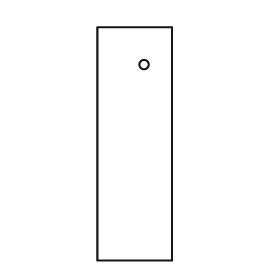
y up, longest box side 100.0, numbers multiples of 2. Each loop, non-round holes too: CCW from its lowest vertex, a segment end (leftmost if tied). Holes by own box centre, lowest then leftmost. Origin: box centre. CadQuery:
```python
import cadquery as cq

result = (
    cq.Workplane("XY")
    .moveTo(-16.0, -50.0)
    .lineTo(16.0, -50.0)
    .lineTo(16.0, 50.0)
    .lineTo(-16.0, 50.0)
    .close()
    .moveTo(4.0, 34.0)
    .circle(2.0)
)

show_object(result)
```